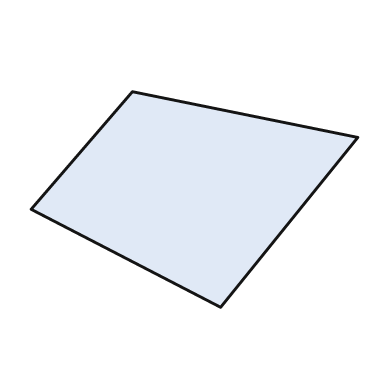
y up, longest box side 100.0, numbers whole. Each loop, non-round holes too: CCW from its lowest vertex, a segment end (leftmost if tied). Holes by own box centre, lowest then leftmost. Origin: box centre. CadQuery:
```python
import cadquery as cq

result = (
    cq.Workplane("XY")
    .moveTo(8.0, -33.0)
    .lineTo(50.0, 19.0)
    .lineTo(-19.0, 33.0)
    .lineTo(-50.0, -3.0)
    .close()
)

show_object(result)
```